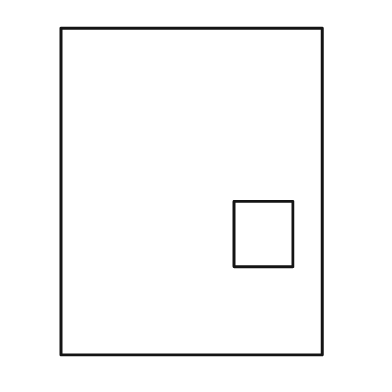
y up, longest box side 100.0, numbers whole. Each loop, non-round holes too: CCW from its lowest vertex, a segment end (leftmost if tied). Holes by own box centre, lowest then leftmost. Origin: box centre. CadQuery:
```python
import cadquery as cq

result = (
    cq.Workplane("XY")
    .moveTo(-40.0, -50.0)
    .lineTo(40.0, -50.0)
    .lineTo(40.0, 50.0)
    .lineTo(-40.0, 50.0)
    .close()
    .moveTo(13.0, -23.0)
    .lineTo(31.0, -23.0)
    .lineTo(31.0, -3.0)
    .lineTo(13.0, -3.0)
    .close()
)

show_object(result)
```